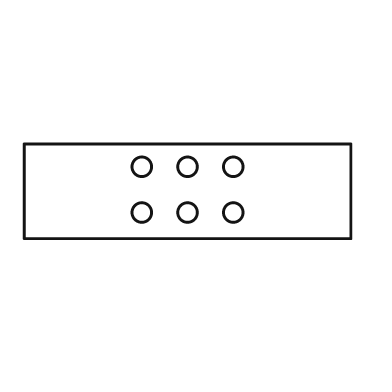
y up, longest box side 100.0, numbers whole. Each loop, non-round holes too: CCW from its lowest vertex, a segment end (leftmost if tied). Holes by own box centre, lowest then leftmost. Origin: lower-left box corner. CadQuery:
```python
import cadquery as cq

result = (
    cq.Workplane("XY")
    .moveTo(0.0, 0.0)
    .lineTo(100.0, 0.0)
    .lineTo(100.0, 29.0)
    .lineTo(0.0, 29.0)
    .close()
    .moveTo(36.0, 8.0)
    .circle(3.0)
    .moveTo(50.0, 8.0)
    .circle(3.0)
    .moveTo(64.0, 8.0)
    .circle(3.0)
    .moveTo(36.0, 22.0)
    .circle(3.0)
    .moveTo(50.0, 22.0)
    .circle(3.0)
    .moveTo(64.0, 22.0)
    .circle(3.0)
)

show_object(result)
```